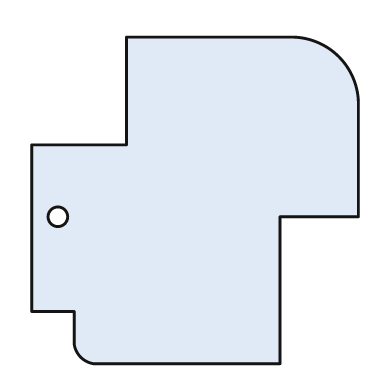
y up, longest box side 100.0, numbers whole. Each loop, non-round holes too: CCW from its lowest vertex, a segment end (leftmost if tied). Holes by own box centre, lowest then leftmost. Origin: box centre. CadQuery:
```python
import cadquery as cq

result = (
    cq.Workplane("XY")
    .moveTo(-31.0, -50.0)
    .lineTo(26.0, -50.0)
    .lineTo(26.0, -5.0)
    .lineTo(50.0, -5.0)
    .lineTo(50.0, 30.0)
    .threePointArc((44.0, 44.0), (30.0, 50.0))
    .lineTo(-21.0, 50.0)
    .lineTo(-21.0, 17.0)
    .lineTo(-50.0, 17.0)
    .lineTo(-50.0, -34.0)
    .lineTo(-37.0, -34.0)
    .lineTo(-37.0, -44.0)
    .threePointArc((-35.0, -48.0), (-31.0, -50.0))
    .close()
    .moveTo(-42.0, -5.0)
    .circle(3.0)
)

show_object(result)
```